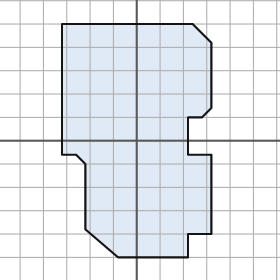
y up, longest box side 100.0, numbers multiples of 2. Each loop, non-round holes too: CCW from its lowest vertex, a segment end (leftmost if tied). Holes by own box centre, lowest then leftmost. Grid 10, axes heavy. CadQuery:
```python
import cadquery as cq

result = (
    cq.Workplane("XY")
    .moveTo(-8.0, -50.0)
    .lineTo(22.0, -50.0)
    .lineTo(22.0, -40.0)
    .lineTo(32.0, -40.0)
    .lineTo(32.0, -6.0)
    .lineTo(22.0, -6.0)
    .lineTo(22.0, 10.0)
    .lineTo(28.0, 10.0)
    .lineTo(32.0, 14.0)
    .lineTo(32.0, 42.0)
    .lineTo(24.0, 50.0)
    .lineTo(-32.0, 50.0)
    .lineTo(-32.0, -6.0)
    .lineTo(-26.0, -6.0)
    .lineTo(-22.0, -10.0)
    .lineTo(-22.0, -38.0)
    .close()
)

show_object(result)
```